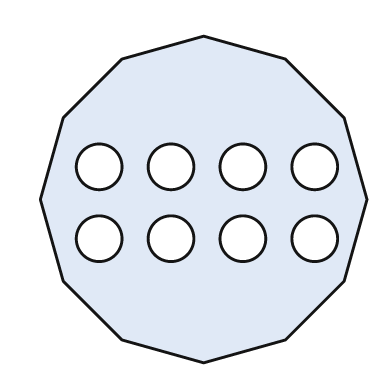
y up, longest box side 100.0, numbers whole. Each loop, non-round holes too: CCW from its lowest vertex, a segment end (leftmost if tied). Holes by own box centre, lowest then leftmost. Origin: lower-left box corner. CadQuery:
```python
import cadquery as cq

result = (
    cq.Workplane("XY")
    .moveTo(50.0, 0.0)
    .lineTo(75.0, 7.0)
    .lineTo(93.0, 25.0)
    .lineTo(100.0, 50.0)
    .lineTo(93.0, 75.0)
    .lineTo(75.0, 93.0)
    .lineTo(50.0, 100.0)
    .lineTo(25.0, 93.0)
    .lineTo(7.0, 75.0)
    .lineTo(0.0, 50.0)
    .lineTo(7.0, 25.0)
    .lineTo(25.0, 7.0)
    .close()
    .moveTo(18.0, 38.0)
    .circle(7.0)
    .moveTo(40.0, 38.0)
    .circle(7.0)
    .moveTo(62.0, 38.0)
    .circle(7.0)
    .moveTo(84.0, 38.0)
    .circle(7.0)
    .moveTo(18.0, 60.0)
    .circle(7.0)
    .moveTo(40.0, 60.0)
    .circle(7.0)
    .moveTo(62.0, 60.0)
    .circle(7.0)
    .moveTo(84.0, 60.0)
    .circle(7.0)
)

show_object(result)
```